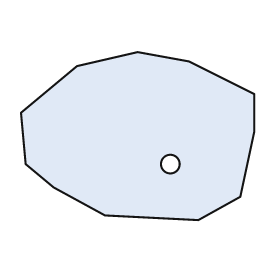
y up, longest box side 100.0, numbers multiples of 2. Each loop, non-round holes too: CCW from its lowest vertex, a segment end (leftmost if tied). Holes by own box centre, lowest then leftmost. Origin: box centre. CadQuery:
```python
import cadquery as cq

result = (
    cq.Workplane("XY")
    .moveTo(26.0, -36.0)
    .lineTo(44.0, -26.0)
    .lineTo(50.0, 2.0)
    .lineTo(50.0, 18.0)
    .lineTo(22.0, 32.0)
    .lineTo(0.0, 36.0)
    .lineTo(-26.0, 30.0)
    .lineTo(-50.0, 10.0)
    .lineTo(-48.0, -12.0)
    .lineTo(-36.0, -22.0)
    .lineTo(-14.0, -34.0)
    .close()
    .moveTo(14.0, -12.0)
    .circle(4.0)
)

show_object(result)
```